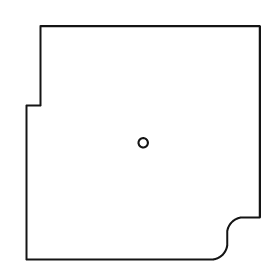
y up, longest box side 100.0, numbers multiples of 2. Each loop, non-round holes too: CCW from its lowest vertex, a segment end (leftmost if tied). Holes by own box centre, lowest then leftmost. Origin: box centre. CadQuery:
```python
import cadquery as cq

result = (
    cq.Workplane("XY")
    .moveTo(-50.0, -50.0)
    .lineTo(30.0, -50.0)
    .threePointArc((34.0, -48.0), (36.0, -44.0))
    .lineTo(36.0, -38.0)
    .threePointArc((38.0, -34.0), (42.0, -32.0))
    .lineTo(50.0, -32.0)
    .lineTo(50.0, 50.0)
    .lineTo(-44.0, 50.0)
    .lineTo(-44.0, 16.0)
    .lineTo(-50.0, 16.0)
    .close()
    .moveTo(0.0, 0.0)
    .circle(2.0)
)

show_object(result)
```